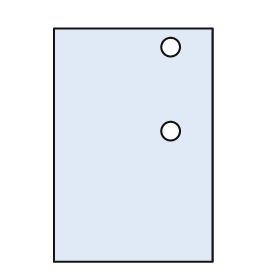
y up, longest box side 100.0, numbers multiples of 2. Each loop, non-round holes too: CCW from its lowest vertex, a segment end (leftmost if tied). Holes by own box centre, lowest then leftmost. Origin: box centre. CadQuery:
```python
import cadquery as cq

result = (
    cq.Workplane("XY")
    .moveTo(-34.0, -50.0)
    .lineTo(34.0, -50.0)
    .lineTo(34.0, 50.0)
    .lineTo(-34.0, 50.0)
    .close()
    .moveTo(16.0, 6.0)
    .circle(4.0)
    .moveTo(16.0, 42.0)
    .circle(4.0)
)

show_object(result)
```